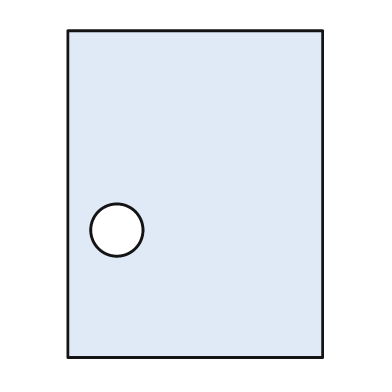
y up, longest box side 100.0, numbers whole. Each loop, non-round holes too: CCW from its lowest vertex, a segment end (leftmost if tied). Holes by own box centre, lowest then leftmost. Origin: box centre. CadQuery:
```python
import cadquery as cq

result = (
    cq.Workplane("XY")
    .moveTo(-39.0, -50.0)
    .lineTo(39.0, -50.0)
    .lineTo(39.0, 50.0)
    .lineTo(-39.0, 50.0)
    .close()
    .moveTo(-24.0, -11.0)
    .circle(8.0)
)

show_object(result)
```